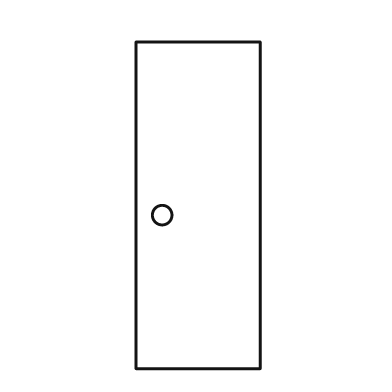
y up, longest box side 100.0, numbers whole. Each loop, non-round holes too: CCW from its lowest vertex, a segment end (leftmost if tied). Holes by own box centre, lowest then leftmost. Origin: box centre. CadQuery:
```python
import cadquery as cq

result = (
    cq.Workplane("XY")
    .moveTo(-19.0, -50.0)
    .lineTo(19.0, -50.0)
    .lineTo(19.0, 50.0)
    .lineTo(-19.0, 50.0)
    .close()
    .moveTo(-11.0, -3.0)
    .circle(3.0)
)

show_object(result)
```